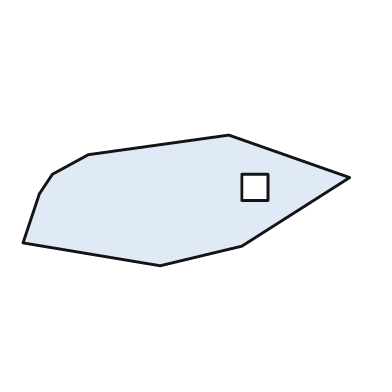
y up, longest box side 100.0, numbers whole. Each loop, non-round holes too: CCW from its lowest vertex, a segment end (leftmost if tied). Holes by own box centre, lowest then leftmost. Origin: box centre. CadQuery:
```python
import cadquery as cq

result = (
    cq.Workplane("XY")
    .moveTo(-8.0, -20.0)
    .lineTo(17.0, -14.0)
    .lineTo(50.0, 7.0)
    .lineTo(13.0, 20.0)
    .lineTo(-30.0, 14.0)
    .lineTo(-41.0, 8.0)
    .lineTo(-45.0, 2.0)
    .lineTo(-50.0, -13.0)
    .close()
    .moveTo(17.0, 0.0)
    .lineTo(25.0, 0.0)
    .lineTo(25.0, 8.0)
    .lineTo(17.0, 8.0)
    .close()
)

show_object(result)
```